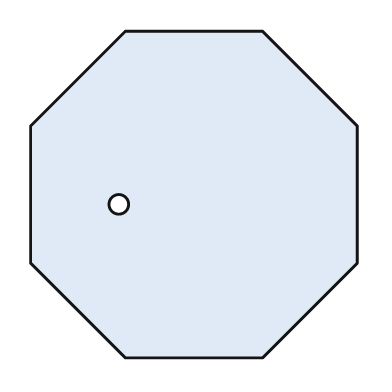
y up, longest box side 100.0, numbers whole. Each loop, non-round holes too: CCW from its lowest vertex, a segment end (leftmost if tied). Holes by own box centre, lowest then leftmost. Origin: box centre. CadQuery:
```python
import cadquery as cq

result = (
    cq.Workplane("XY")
    .moveTo(-21.0, -50.0)
    .lineTo(21.0, -50.0)
    .lineTo(50.0, -21.0)
    .lineTo(50.0, 21.0)
    .lineTo(21.0, 50.0)
    .lineTo(-21.0, 50.0)
    .lineTo(-50.0, 21.0)
    .lineTo(-50.0, -21.0)
    .close()
    .moveTo(-23.0, -3.0)
    .circle(3.0)
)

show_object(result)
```